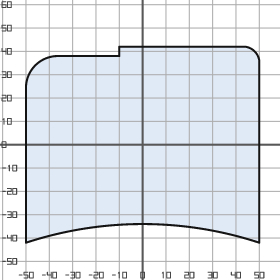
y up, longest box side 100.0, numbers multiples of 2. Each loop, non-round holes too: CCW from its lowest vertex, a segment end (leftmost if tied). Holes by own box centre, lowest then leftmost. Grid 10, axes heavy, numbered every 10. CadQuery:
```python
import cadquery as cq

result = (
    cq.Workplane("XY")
    .moveTo(-50.0, -42.0)
    .threePointArc((0.0, -34.0), (50.0, -42.0))
    .lineTo(50.0, 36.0)
    .threePointArc((48.0, 40.0), (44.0, 42.0))
    .lineTo(-10.0, 42.0)
    .lineTo(-10.0, 38.0)
    .lineTo(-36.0, 38.0)
    .threePointArc((-46.0, 34.0), (-50.0, 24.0))
    .close()
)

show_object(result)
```